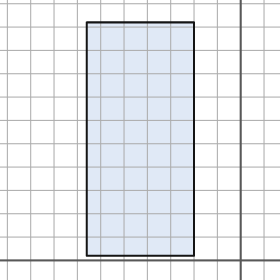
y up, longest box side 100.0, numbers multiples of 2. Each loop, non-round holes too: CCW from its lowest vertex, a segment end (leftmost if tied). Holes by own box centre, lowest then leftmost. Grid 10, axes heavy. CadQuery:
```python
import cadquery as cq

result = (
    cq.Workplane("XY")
    .moveTo(-66.0, 2.0)
    .lineTo(-20.0, 2.0)
    .lineTo(-20.0, 102.0)
    .lineTo(-66.0, 102.0)
    .close()
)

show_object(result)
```